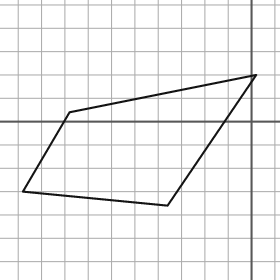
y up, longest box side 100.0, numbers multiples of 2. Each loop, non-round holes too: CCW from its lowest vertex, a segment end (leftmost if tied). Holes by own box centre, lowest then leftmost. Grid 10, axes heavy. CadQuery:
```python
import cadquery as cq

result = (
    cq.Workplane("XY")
    .moveTo(-36.0, -36.0)
    .lineTo(2.0, 20.0)
    .lineTo(-78.0, 4.0)
    .lineTo(-98.0, -30.0)
    .close()
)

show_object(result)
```